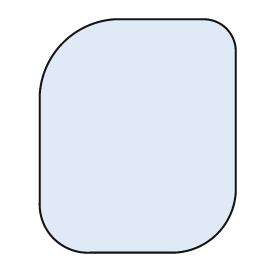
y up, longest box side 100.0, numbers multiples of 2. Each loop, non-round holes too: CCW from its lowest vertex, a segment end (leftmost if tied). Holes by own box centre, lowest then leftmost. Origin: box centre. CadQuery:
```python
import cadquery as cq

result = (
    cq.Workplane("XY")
    .moveTo(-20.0, -50.0)
    .lineTo(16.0, -50.0)
    .threePointArc((34.0, -42.0), (42.0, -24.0))
    .lineTo(42.0, 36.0)
    .threePointArc((38.0, 46.0), (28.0, 50.0))
    .lineTo(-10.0, 50.0)
    .threePointArc((-32.0, 40.0), (-42.0, 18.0))
    .lineTo(-42.0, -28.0)
    .threePointArc((-36.0, -44.0), (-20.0, -50.0))
    .close()
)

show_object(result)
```